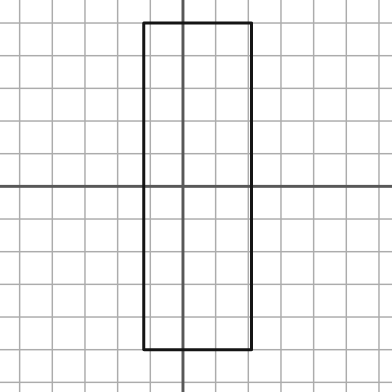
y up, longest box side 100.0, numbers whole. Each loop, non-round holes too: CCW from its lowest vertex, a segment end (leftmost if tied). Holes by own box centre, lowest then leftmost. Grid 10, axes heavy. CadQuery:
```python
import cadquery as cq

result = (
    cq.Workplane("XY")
    .moveTo(-12.0, -50.0)
    .lineTo(21.0, -50.0)
    .lineTo(21.0, 50.0)
    .lineTo(-12.0, 50.0)
    .close()
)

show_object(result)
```